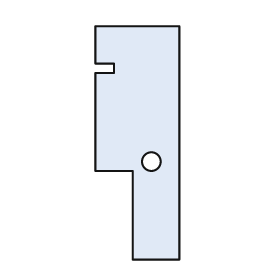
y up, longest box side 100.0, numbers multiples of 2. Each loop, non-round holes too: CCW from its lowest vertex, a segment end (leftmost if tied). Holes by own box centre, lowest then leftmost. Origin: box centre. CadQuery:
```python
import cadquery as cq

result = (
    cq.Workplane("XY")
    .moveTo(-2.0, -50.0)
    .lineTo(18.0, -50.0)
    .lineTo(18.0, 50.0)
    .lineTo(-18.0, 50.0)
    .lineTo(-18.0, 34.0)
    .lineTo(-10.0, 34.0)
    .lineTo(-10.0, 30.0)
    .lineTo(-18.0, 30.0)
    .lineTo(-18.0, -12.0)
    .lineTo(-2.0, -12.0)
    .close()
    .moveTo(6.0, -8.0)
    .circle(4.0)
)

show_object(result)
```